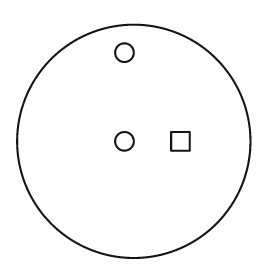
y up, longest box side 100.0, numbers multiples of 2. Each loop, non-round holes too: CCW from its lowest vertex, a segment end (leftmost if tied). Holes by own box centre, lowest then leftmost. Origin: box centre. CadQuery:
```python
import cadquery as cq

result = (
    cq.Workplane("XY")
    .moveTo(0.0, 0.0)
    .circle(50.0)
    .moveTo(-4.0, 0.0)
    .circle(4.0)
    .moveTo(16.0, -4.0)
    .lineTo(24.0, -4.0)
    .lineTo(24.0, 4.0)
    .lineTo(16.0, 4.0)
    .close()
    .moveTo(-4.0, 38.0)
    .circle(4.0)
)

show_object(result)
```